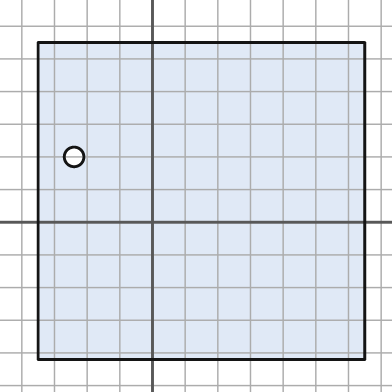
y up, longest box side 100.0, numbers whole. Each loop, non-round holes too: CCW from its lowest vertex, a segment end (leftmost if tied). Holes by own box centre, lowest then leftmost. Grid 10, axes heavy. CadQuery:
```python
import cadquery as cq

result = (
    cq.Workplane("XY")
    .moveTo(-35.0, -42.0)
    .lineTo(65.0, -42.0)
    .lineTo(65.0, 55.0)
    .lineTo(-35.0, 55.0)
    .close()
    .moveTo(-24.0, 20.0)
    .circle(3.0)
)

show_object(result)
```